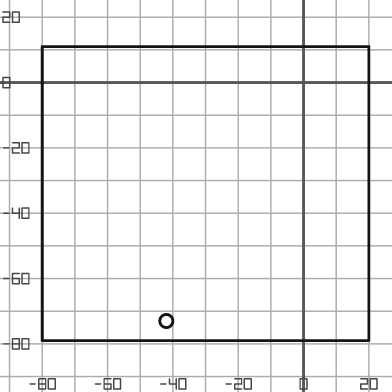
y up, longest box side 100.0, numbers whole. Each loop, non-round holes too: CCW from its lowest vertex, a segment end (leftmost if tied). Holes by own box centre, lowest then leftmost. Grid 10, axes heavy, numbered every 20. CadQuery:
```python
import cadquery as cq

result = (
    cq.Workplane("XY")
    .moveTo(-80.0, -79.0)
    .lineTo(20.0, -79.0)
    .lineTo(20.0, 11.0)
    .lineTo(-80.0, 11.0)
    .close()
    .moveTo(-42.0, -73.0)
    .circle(2.0)
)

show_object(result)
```